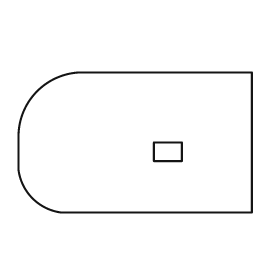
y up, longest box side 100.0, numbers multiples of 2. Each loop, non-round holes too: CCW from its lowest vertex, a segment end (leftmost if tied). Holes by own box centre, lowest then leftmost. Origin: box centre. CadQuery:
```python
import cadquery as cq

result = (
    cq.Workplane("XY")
    .moveTo(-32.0, -30.0)
    .lineTo(50.0, -30.0)
    .lineTo(50.0, 30.0)
    .lineTo(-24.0, 30.0)
    .threePointArc((-42.0, 22.0), (-50.0, 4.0))
    .lineTo(-50.0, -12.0)
    .threePointArc((-44.0, -24.0), (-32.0, -30.0))
    .close()
    .moveTo(8.0, -8.0)
    .lineTo(20.0, -8.0)
    .lineTo(20.0, 0.0)
    .lineTo(8.0, 0.0)
    .close()
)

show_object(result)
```